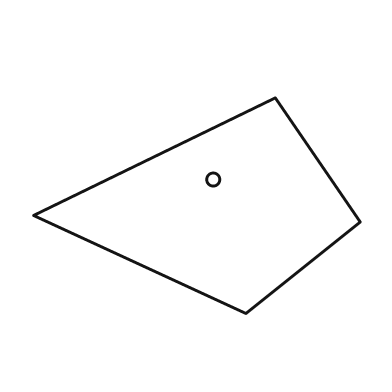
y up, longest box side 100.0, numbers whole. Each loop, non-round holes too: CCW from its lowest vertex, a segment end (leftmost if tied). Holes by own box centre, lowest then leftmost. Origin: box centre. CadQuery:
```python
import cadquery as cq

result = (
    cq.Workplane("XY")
    .moveTo(15.0, -33.0)
    .lineTo(50.0, -5.0)
    .lineTo(24.0, 33.0)
    .lineTo(-50.0, -3.0)
    .close()
    .moveTo(5.0, 8.0)
    .circle(2.0)
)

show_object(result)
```